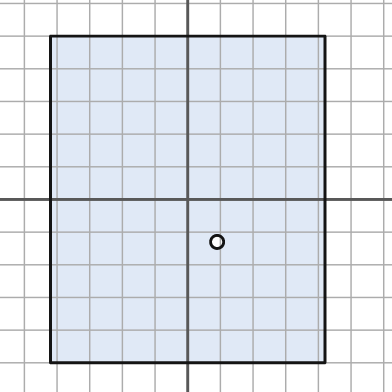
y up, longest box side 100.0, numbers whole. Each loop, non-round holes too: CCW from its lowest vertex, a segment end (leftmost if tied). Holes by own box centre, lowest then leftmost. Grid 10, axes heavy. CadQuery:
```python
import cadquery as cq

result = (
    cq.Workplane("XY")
    .moveTo(-42.0, -50.0)
    .lineTo(42.0, -50.0)
    .lineTo(42.0, 50.0)
    .lineTo(-42.0, 50.0)
    .close()
    .moveTo(9.0, -13.0)
    .circle(2.0)
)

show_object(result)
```